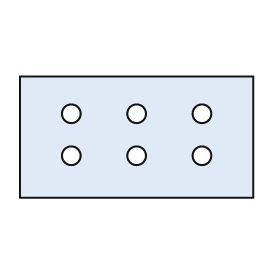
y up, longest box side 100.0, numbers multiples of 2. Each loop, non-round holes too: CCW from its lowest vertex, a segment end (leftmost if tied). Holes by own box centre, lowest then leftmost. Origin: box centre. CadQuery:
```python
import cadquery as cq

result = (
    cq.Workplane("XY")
    .moveTo(-50.0, -26.0)
    .lineTo(50.0, -26.0)
    .lineTo(50.0, 26.0)
    .lineTo(-50.0, 26.0)
    .close()
    .moveTo(-28.0, -8.0)
    .circle(4.0)
    .moveTo(0.0, -8.0)
    .circle(4.0)
    .moveTo(28.0, -8.0)
    .circle(4.0)
    .moveTo(-28.0, 10.0)
    .circle(4.0)
    .moveTo(0.0, 10.0)
    .circle(4.0)
    .moveTo(28.0, 10.0)
    .circle(4.0)
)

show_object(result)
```